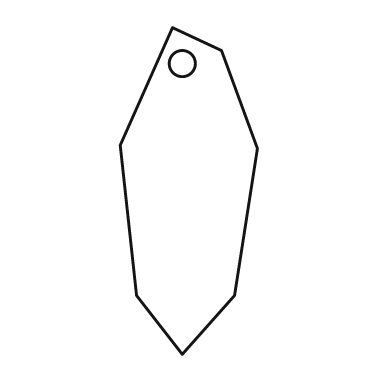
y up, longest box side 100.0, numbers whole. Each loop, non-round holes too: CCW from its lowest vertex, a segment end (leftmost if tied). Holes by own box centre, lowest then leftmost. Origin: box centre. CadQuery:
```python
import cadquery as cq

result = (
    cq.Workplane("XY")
    .moveTo(-2.0, -50.0)
    .lineTo(14.0, -32.0)
    .lineTo(21.0, 13.0)
    .lineTo(10.0, 43.0)
    .lineTo(-5.0, 50.0)
    .lineTo(-21.0, 14.0)
    .lineTo(-16.0, -32.0)
    .close()
    .moveTo(-2.0, 39.0)
    .circle(4.0)
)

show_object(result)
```